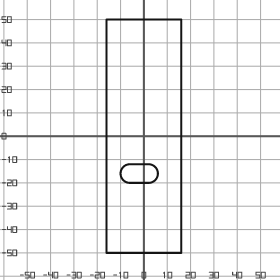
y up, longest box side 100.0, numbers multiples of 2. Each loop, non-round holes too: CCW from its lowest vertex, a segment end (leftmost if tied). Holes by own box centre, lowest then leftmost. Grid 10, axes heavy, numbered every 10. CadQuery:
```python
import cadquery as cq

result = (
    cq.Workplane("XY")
    .moveTo(-16.0, -50.0)
    .lineTo(16.0, -50.0)
    .lineTo(16.0, 50.0)
    .lineTo(-16.0, 50.0)
    .close()
    .moveTo(-6.0, -20.0)
    .lineTo(2.0, -20.0)
    .threePointArc((6.0, -16.0), (2.0, -12.0))
    .lineTo(-6.0, -12.0)
    .threePointArc((-10.0, -16.0), (-6.0, -20.0))
    .close()
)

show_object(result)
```